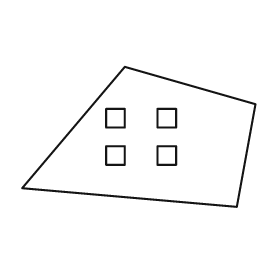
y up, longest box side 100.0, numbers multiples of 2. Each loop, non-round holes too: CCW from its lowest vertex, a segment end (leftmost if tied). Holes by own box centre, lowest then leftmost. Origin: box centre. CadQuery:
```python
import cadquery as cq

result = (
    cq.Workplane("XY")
    .moveTo(42.0, -30.0)
    .lineTo(50.0, 14.0)
    .lineTo(-6.0, 30.0)
    .lineTo(-50.0, -22.0)
    .close()
    .moveTo(-14.0, -12.0)
    .lineTo(-6.0, -12.0)
    .lineTo(-6.0, -4.0)
    .lineTo(-14.0, -4.0)
    .close()
    .moveTo(8.0, -12.0)
    .lineTo(16.0, -12.0)
    .lineTo(16.0, -4.0)
    .lineTo(8.0, -4.0)
    .close()
    .moveTo(-14.0, 4.0)
    .lineTo(-6.0, 4.0)
    .lineTo(-6.0, 12.0)
    .lineTo(-14.0, 12.0)
    .close()
    .moveTo(8.0, 4.0)
    .lineTo(16.0, 4.0)
    .lineTo(16.0, 12.0)
    .lineTo(8.0, 12.0)
    .close()
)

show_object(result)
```